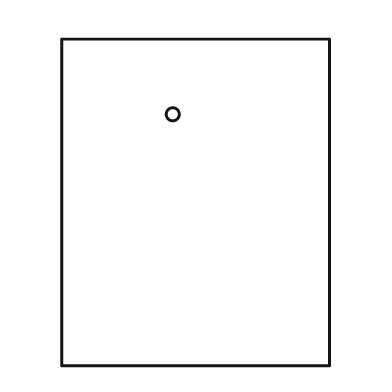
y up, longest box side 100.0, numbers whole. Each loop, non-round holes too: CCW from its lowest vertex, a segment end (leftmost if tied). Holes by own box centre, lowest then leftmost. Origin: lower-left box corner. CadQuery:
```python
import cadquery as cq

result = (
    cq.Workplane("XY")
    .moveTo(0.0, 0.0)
    .lineTo(82.0, 0.0)
    .lineTo(82.0, 100.0)
    .lineTo(0.0, 100.0)
    .close()
    .moveTo(34.0, 77.0)
    .circle(2.0)
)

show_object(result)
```